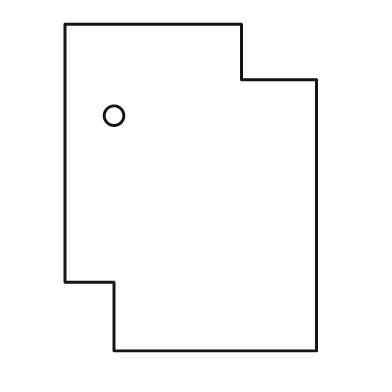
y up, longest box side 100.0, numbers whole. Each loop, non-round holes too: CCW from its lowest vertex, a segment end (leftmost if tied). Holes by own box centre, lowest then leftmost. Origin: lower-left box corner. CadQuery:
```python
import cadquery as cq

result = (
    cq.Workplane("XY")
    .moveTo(15.0, 0.0)
    .lineTo(77.0, 0.0)
    .lineTo(77.0, 83.0)
    .lineTo(54.0, 83.0)
    .lineTo(54.0, 100.0)
    .lineTo(0.0, 100.0)
    .lineTo(0.0, 21.0)
    .lineTo(15.0, 21.0)
    .close()
    .moveTo(15.0, 72.0)
    .circle(3.0)
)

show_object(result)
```